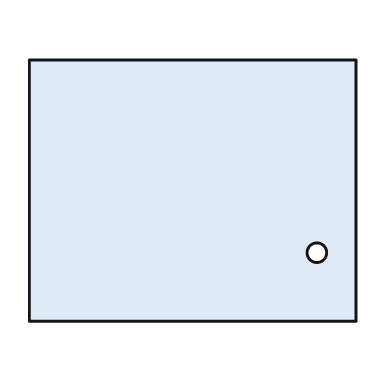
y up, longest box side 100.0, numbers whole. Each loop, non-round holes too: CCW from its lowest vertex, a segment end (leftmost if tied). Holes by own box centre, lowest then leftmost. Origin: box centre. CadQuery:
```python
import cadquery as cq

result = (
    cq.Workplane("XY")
    .moveTo(-50.0, -40.0)
    .lineTo(50.0, -40.0)
    .lineTo(50.0, 40.0)
    .lineTo(-50.0, 40.0)
    .close()
    .moveTo(38.0, -19.0)
    .circle(3.0)
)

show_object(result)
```